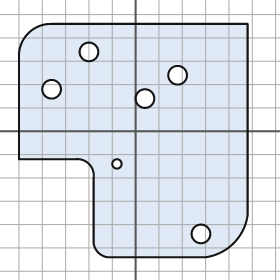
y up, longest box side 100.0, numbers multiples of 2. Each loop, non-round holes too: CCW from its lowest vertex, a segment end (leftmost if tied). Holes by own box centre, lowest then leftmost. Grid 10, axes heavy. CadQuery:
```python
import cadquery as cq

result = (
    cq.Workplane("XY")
    .moveTo(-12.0, -54.0)
    .lineTo(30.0, -54.0)
    .threePointArc((42.0, -48.0), (48.0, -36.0))
    .lineTo(48.0, 46.0)
    .lineTo(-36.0, 46.0)
    .threePointArc((-46.0, 42.0), (-50.0, 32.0))
    .lineTo(-50.0, -12.0)
    .lineTo(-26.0, -12.0)
    .threePointArc((-20.0, -14.0), (-18.0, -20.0))
    .lineTo(-18.0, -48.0)
    .threePointArc((-16.0, -52.0), (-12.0, -54.0))
    .close()
    .moveTo(28.0, -44.0)
    .circle(4.0)
    .moveTo(-8.0, -14.0)
    .circle(2.0)
    .moveTo(4.0, 14.0)
    .circle(4.0)
    .moveTo(-36.0, 18.0)
    .circle(4.0)
    .moveTo(18.0, 24.0)
    .circle(4.0)
    .moveTo(-20.0, 34.0)
    .circle(4.0)
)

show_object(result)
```